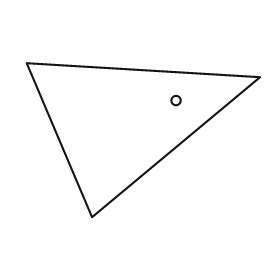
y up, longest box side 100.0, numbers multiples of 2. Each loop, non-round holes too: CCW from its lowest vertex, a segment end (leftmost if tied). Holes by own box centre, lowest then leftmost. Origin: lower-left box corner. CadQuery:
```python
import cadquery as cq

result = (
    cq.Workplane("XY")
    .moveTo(28.0, 0.0)
    .lineTo(100.0, 60.0)
    .lineTo(0.0, 66.0)
    .close()
    .moveTo(64.0, 50.0)
    .circle(2.0)
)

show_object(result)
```